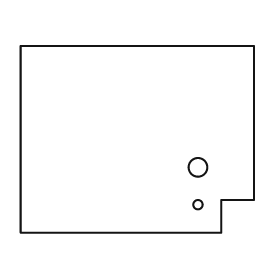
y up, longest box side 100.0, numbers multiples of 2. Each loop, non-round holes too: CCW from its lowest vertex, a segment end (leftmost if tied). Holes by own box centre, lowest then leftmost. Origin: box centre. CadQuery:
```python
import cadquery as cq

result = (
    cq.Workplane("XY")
    .moveTo(-50.0, -40.0)
    .lineTo(36.0, -40.0)
    .lineTo(36.0, -26.0)
    .lineTo(50.0, -26.0)
    .lineTo(50.0, 40.0)
    .lineTo(-50.0, 40.0)
    .close()
    .moveTo(26.0, -28.0)
    .circle(2.0)
    .moveTo(26.0, -12.0)
    .circle(4.0)
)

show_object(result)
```